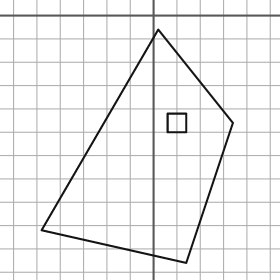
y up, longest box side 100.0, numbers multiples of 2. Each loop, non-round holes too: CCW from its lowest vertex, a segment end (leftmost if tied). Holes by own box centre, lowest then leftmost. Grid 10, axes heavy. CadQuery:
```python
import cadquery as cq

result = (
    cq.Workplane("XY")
    .moveTo(14.0, -106.0)
    .lineTo(34.0, -46.0)
    .lineTo(2.0, -6.0)
    .lineTo(-48.0, -92.0)
    .close()
    .moveTo(6.0, -50.0)
    .lineTo(14.0, -50.0)
    .lineTo(14.0, -42.0)
    .lineTo(6.0, -42.0)
    .close()
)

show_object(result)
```